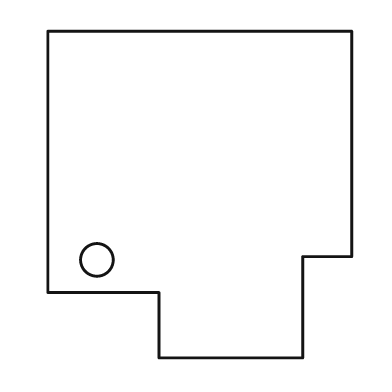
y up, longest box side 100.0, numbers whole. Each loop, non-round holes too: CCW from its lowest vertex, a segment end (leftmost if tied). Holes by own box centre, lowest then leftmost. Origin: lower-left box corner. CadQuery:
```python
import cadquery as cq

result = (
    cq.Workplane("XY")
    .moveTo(34.0, 0.0)
    .lineTo(78.0, 0.0)
    .lineTo(78.0, 31.0)
    .lineTo(93.0, 31.0)
    .lineTo(93.0, 100.0)
    .lineTo(0.0, 100.0)
    .lineTo(0.0, 20.0)
    .lineTo(34.0, 20.0)
    .close()
    .moveTo(15.0, 30.0)
    .circle(5.0)
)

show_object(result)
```